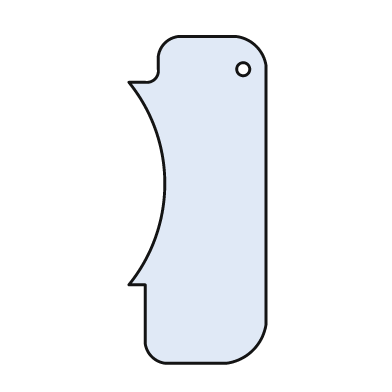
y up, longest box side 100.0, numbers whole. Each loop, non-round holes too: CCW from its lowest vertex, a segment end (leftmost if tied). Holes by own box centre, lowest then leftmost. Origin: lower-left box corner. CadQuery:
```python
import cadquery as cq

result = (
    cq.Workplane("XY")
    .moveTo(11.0, 0.0)
    .lineTo(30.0, 0.0)
    .threePointArc((38.0, 4.0), (42.0, 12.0))
    .lineTo(42.0, 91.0)
    .threePointArc((39.0, 97.0), (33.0, 100.0))
    .lineTo(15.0, 100.0)
    .threePointArc((11.0, 98.0), (9.0, 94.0))
    .lineTo(9.0, 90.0)
    .threePointArc((8.0, 87.0), (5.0, 86.0))
    .lineTo(0.0, 86.0)
    .threePointArc((11.0, 55.0), (0.0, 24.0))
    .lineTo(5.0, 24.0)
    .lineTo(5.0, 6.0)
    .threePointArc((7.0, 2.0), (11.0, 0.0))
    .close()
    .moveTo(35.0, 90.0)
    .circle(2.0)
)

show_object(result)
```